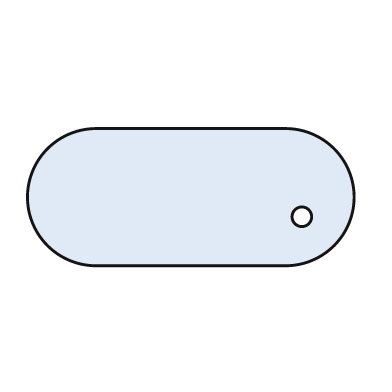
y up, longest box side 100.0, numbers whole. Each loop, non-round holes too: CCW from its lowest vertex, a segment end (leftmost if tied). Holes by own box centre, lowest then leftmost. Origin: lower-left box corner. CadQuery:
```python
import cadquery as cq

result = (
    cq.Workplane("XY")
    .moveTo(21.0, 0.0)
    .lineTo(79.0, 0.0)
    .threePointArc((100.0, 21.0), (79.0, 42.0))
    .lineTo(21.0, 42.0)
    .threePointArc((0.0, 21.0), (21.0, 0.0))
    .close()
    .moveTo(84.0, 15.0)
    .circle(3.0)
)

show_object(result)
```